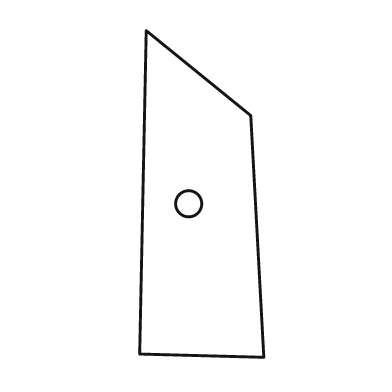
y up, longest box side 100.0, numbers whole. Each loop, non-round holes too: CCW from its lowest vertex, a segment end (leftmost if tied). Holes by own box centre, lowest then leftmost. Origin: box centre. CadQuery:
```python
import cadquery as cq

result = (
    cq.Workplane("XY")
    .moveTo(19.0, -50.0)
    .lineTo(15.0, 24.0)
    .lineTo(-17.0, 50.0)
    .lineTo(-19.0, -49.0)
    .close()
    .moveTo(-4.0, -3.0)
    .circle(4.0)
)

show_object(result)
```